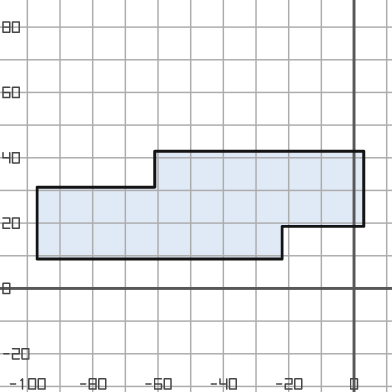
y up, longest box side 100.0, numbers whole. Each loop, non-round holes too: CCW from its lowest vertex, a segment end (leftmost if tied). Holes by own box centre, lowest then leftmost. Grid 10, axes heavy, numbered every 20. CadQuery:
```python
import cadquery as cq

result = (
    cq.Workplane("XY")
    .moveTo(-97.0, 9.0)
    .lineTo(-22.0, 9.0)
    .lineTo(-22.0, 19.0)
    .lineTo(3.0, 19.0)
    .lineTo(3.0, 42.0)
    .lineTo(-61.0, 42.0)
    .lineTo(-61.0, 31.0)
    .lineTo(-97.0, 31.0)
    .close()
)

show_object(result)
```